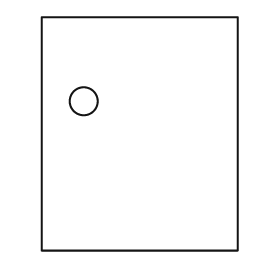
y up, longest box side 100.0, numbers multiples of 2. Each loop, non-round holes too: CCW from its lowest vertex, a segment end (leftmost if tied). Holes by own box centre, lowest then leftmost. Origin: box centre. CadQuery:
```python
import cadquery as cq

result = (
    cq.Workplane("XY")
    .moveTo(-42.0, -50.0)
    .lineTo(42.0, -50.0)
    .lineTo(42.0, 50.0)
    .lineTo(-42.0, 50.0)
    .close()
    .moveTo(-24.0, 14.0)
    .circle(6.0)
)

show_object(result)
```